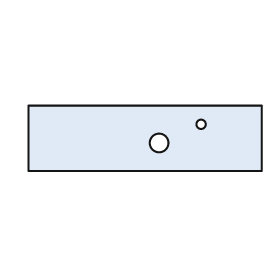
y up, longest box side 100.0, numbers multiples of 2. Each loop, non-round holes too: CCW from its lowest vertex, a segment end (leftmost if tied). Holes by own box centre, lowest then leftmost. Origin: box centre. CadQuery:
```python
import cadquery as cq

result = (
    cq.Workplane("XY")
    .moveTo(-50.0, -14.0)
    .lineTo(50.0, -14.0)
    .lineTo(50.0, 14.0)
    .lineTo(-50.0, 14.0)
    .close()
    .moveTo(6.0, -2.0)
    .circle(4.0)
    .moveTo(24.0, 6.0)
    .circle(2.0)
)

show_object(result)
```